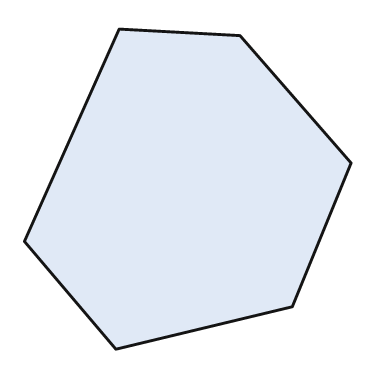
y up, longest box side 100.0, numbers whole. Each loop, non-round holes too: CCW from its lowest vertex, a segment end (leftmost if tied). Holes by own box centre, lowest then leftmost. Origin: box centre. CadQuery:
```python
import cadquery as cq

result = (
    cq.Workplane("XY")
    .moveTo(-22.0, -49.0)
    .lineTo(32.0, -36.0)
    .lineTo(50.0, 8.0)
    .lineTo(16.0, 47.0)
    .lineTo(-21.0, 49.0)
    .lineTo(-50.0, -16.0)
    .close()
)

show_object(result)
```